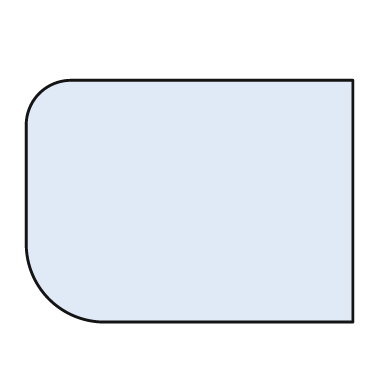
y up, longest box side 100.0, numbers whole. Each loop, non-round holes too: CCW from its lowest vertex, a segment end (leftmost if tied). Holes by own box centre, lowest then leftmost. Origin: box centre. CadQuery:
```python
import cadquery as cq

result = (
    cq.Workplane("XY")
    .moveTo(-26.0, -37.0)
    .lineTo(50.0, -37.0)
    .lineTo(50.0, 37.0)
    .lineTo(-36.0, 37.0)
    .threePointArc((-46.0, 33.0), (-50.0, 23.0))
    .lineTo(-50.0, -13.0)
    .threePointArc((-43.0, -30.0), (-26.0, -37.0))
    .close()
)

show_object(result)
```